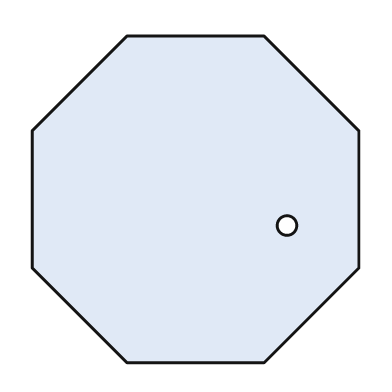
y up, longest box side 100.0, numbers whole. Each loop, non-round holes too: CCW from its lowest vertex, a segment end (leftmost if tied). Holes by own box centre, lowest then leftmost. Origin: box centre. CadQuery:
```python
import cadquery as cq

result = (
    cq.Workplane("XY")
    .moveTo(-21.0, -50.0)
    .lineTo(21.0, -50.0)
    .lineTo(50.0, -21.0)
    .lineTo(50.0, 21.0)
    .lineTo(21.0, 50.0)
    .lineTo(-21.0, 50.0)
    .lineTo(-50.0, 21.0)
    .lineTo(-50.0, -21.0)
    .close()
    .moveTo(28.0, -8.0)
    .circle(3.0)
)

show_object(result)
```